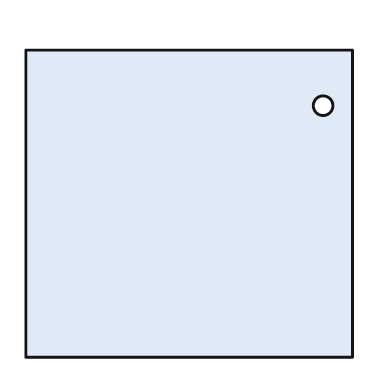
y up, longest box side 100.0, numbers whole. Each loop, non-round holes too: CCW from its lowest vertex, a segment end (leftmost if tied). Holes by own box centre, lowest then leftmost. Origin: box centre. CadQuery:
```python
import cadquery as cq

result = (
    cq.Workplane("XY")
    .moveTo(-50.0, -47.0)
    .lineTo(50.0, -47.0)
    .lineTo(50.0, 47.0)
    .lineTo(-50.0, 47.0)
    .close()
    .moveTo(41.0, 30.0)
    .circle(3.0)
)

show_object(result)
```